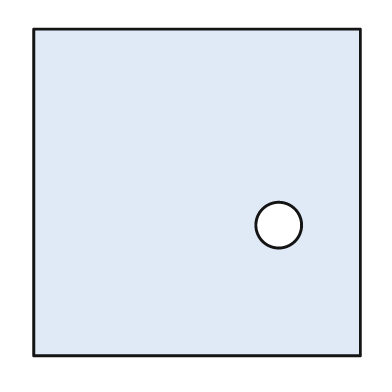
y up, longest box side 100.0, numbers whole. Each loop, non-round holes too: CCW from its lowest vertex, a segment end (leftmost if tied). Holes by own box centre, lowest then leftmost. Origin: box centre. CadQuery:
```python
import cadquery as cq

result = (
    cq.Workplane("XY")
    .moveTo(-50.0, -50.0)
    .lineTo(50.0, -50.0)
    .lineTo(50.0, 50.0)
    .lineTo(-50.0, 50.0)
    .close()
    .moveTo(25.0, -10.0)
    .circle(7.0)
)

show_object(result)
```